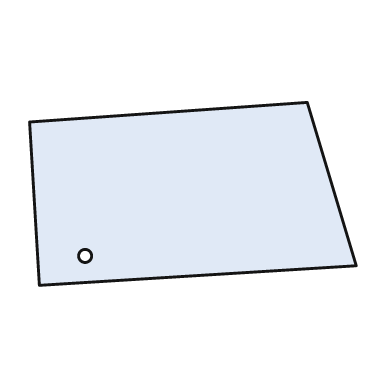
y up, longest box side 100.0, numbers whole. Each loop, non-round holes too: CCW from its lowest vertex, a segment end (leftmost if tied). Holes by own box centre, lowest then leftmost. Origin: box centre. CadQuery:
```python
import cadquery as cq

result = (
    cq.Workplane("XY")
    .moveTo(-47.0, -28.0)
    .lineTo(50.0, -22.0)
    .lineTo(35.0, 28.0)
    .lineTo(-50.0, 22.0)
    .close()
    .moveTo(-33.0, -19.0)
    .circle(2.0)
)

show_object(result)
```